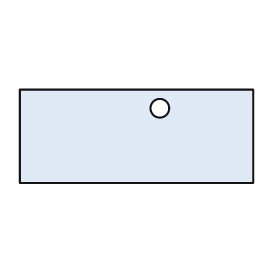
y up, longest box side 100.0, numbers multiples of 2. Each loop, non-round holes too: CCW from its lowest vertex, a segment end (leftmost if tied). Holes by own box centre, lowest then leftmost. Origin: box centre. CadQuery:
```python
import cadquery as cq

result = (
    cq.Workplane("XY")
    .moveTo(-50.0, -20.0)
    .lineTo(50.0, -20.0)
    .lineTo(50.0, 20.0)
    .lineTo(-50.0, 20.0)
    .close()
    .moveTo(10.0, 12.0)
    .circle(4.0)
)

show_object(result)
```